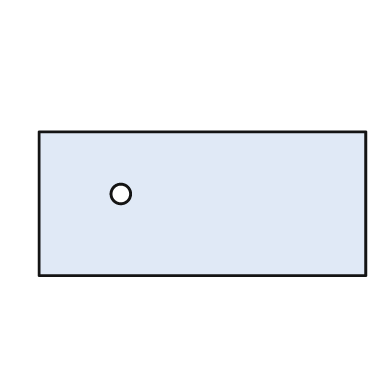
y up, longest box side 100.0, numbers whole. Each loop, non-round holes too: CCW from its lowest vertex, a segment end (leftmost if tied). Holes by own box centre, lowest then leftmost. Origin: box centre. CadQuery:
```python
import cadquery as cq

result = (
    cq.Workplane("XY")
    .moveTo(-50.0, -22.0)
    .lineTo(50.0, -22.0)
    .lineTo(50.0, 22.0)
    .lineTo(-50.0, 22.0)
    .close()
    .moveTo(-25.0, 3.0)
    .circle(3.0)
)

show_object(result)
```